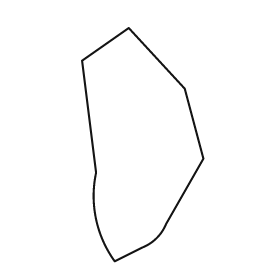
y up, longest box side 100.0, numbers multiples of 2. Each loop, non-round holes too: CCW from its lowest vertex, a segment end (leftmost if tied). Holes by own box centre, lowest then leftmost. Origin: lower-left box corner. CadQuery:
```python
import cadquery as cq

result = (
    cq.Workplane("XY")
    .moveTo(14.0, 0.0)
    .lineTo(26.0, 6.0)
    .threePointArc((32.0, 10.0), (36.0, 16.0))
    .lineTo(52.0, 44.0)
    .lineTo(44.0, 74.0)
    .lineTo(20.0, 100.0)
    .lineTo(0.0, 86.0)
    .lineTo(6.0, 38.0)
    .threePointArc((6.0, 18.0), (14.0, 0.0))
    .close()
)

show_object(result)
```